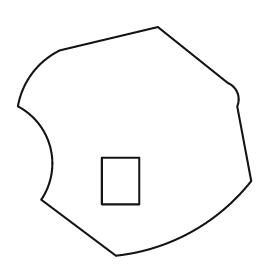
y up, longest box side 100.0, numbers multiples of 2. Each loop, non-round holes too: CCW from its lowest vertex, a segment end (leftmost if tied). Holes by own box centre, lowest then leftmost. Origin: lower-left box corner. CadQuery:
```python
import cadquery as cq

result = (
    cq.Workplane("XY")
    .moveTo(42.0, 0.0)
    .threePointArc((74.0, 10.0), (100.0, 32.0))
    .lineTo(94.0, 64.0)
    .threePointArc((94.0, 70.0), (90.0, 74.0))
    .lineTo(60.0, 98.0)
    .lineTo(18.0, 88.0)
    .threePointArc((6.0, 78.0), (0.0, 64.0))
    .threePointArc((14.0, 46.0), (10.0, 24.0))
    .close()
    .moveTo(36.0, 22.0)
    .lineTo(52.0, 22.0)
    .lineTo(52.0, 42.0)
    .lineTo(36.0, 42.0)
    .close()
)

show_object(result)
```